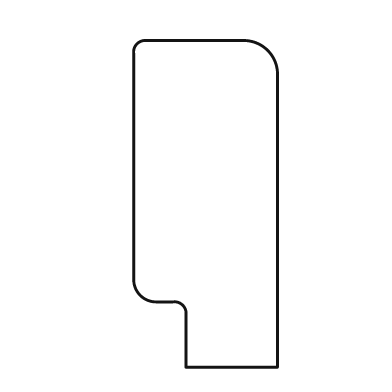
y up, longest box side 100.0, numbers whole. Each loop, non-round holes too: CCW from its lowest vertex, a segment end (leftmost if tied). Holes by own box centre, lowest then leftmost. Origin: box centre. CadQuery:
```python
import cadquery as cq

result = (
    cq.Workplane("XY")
    .moveTo(-6.0, -50.0)
    .lineTo(22.0, -50.0)
    .lineTo(22.0, 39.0)
    .threePointArc((19.0, 47.0), (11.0, 50.0))
    .lineTo(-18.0, 50.0)
    .threePointArc((-21.0, 49.0), (-22.0, 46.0))
    .lineTo(-22.0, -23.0)
    .threePointArc((-20.0, -28.0), (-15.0, -30.0))
    .lineTo(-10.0, -30.0)
    .threePointArc((-7.0, -31.0), (-6.0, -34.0))
    .close()
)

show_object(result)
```